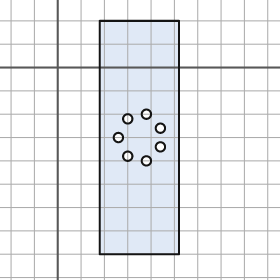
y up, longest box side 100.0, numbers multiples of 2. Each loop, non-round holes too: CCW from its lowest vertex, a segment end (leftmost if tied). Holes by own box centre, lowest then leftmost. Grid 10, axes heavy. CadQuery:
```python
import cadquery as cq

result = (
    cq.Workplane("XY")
    .moveTo(18.0, -80.0)
    .lineTo(52.0, -80.0)
    .lineTo(52.0, 20.0)
    .lineTo(18.0, 20.0)
    .close()
    .moveTo(38.0, -40.0)
    .circle(2.0)
    .moveTo(30.0, -38.0)
    .circle(2.0)
    .moveTo(44.0, -34.0)
    .circle(2.0)
    .moveTo(26.0, -30.0)
    .circle(2.0)
    .moveTo(44.0, -26.0)
    .circle(2.0)
    .moveTo(30.0, -22.0)
    .circle(2.0)
    .moveTo(38.0, -20.0)
    .circle(2.0)
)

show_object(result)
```